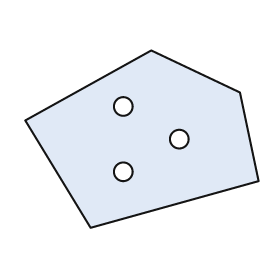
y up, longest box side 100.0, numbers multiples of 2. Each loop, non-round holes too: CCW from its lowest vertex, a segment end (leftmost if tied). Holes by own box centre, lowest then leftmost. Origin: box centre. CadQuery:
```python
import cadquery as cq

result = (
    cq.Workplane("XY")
    .moveTo(-22.0, -38.0)
    .lineTo(50.0, -18.0)
    .lineTo(42.0, 20.0)
    .lineTo(4.0, 38.0)
    .lineTo(-50.0, 8.0)
    .close()
    .moveTo(-8.0, -14.0)
    .circle(4.0)
    .moveTo(16.0, 0.0)
    .circle(4.0)
    .moveTo(-8.0, 14.0)
    .circle(4.0)
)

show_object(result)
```